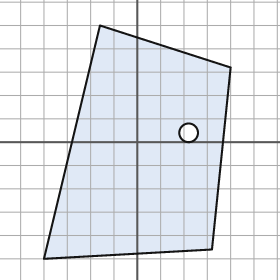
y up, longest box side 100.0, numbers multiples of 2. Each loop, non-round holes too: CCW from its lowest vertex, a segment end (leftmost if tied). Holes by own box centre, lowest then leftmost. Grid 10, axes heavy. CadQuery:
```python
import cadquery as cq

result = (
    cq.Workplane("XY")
    .moveTo(-40.0, -50.0)
    .lineTo(32.0, -46.0)
    .lineTo(40.0, 32.0)
    .lineTo(-16.0, 50.0)
    .close()
    .moveTo(22.0, 4.0)
    .circle(4.0)
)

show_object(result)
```